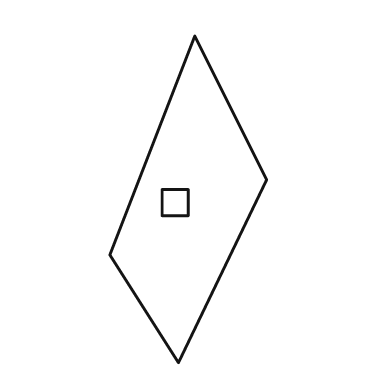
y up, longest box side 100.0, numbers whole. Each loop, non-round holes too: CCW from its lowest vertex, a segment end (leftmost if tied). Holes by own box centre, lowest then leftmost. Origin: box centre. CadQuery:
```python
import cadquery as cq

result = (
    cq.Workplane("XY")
    .moveTo(-3.0, -50.0)
    .lineTo(24.0, 6.0)
    .lineTo(2.0, 50.0)
    .lineTo(-24.0, -17.0)
    .close()
    .moveTo(-8.0, -5.0)
    .lineTo(0.0, -5.0)
    .lineTo(0.0, 3.0)
    .lineTo(-8.0, 3.0)
    .close()
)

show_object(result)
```